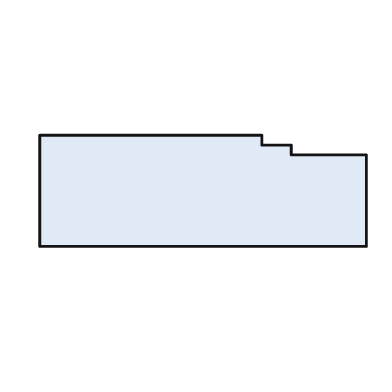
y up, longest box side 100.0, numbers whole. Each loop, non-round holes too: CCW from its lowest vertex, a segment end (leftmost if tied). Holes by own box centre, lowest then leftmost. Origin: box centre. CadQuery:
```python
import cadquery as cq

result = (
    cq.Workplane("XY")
    .moveTo(-50.0, -17.0)
    .lineTo(50.0, -17.0)
    .lineTo(50.0, 11.0)
    .lineTo(27.0, 11.0)
    .lineTo(27.0, 14.0)
    .lineTo(18.0, 14.0)
    .lineTo(18.0, 17.0)
    .lineTo(-50.0, 17.0)
    .close()
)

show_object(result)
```